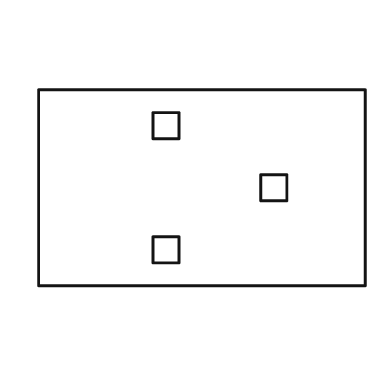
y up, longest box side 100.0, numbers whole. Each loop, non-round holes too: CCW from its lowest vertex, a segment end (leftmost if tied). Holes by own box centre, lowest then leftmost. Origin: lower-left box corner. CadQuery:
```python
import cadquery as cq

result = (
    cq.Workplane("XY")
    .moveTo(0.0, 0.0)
    .lineTo(100.0, 0.0)
    .lineTo(100.0, 60.0)
    .lineTo(0.0, 60.0)
    .close()
    .moveTo(35.0, 7.0)
    .lineTo(43.0, 7.0)
    .lineTo(43.0, 15.0)
    .lineTo(35.0, 15.0)
    .close()
    .moveTo(68.0, 26.0)
    .lineTo(76.0, 26.0)
    .lineTo(76.0, 34.0)
    .lineTo(68.0, 34.0)
    .close()
    .moveTo(35.0, 45.0)
    .lineTo(43.0, 45.0)
    .lineTo(43.0, 53.0)
    .lineTo(35.0, 53.0)
    .close()
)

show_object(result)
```